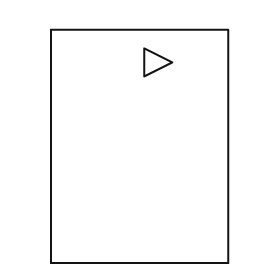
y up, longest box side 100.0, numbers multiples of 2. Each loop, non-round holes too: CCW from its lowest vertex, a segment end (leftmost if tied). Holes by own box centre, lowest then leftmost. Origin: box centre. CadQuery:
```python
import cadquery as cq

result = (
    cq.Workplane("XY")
    .moveTo(-38.0, -50.0)
    .lineTo(38.0, -50.0)
    .lineTo(38.0, 50.0)
    .lineTo(-38.0, 50.0)
    .close()
    .moveTo(2.0, 30.0)
    .lineTo(14.0, 36.0)
    .lineTo(2.0, 42.0)
    .close()
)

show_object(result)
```